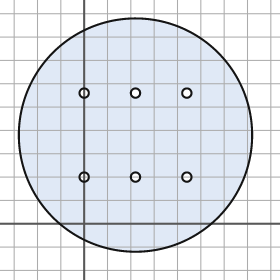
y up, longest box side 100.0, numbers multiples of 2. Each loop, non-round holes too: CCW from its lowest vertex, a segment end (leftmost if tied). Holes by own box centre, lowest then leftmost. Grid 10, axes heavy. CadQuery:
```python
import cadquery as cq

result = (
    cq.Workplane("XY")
    .moveTo(22.0, 38.0)
    .circle(50.0)
    .moveTo(0.0, 20.0)
    .circle(2.0)
    .moveTo(22.0, 20.0)
    .circle(2.0)
    .moveTo(44.0, 20.0)
    .circle(2.0)
    .moveTo(0.0, 56.0)
    .circle(2.0)
    .moveTo(22.0, 56.0)
    .circle(2.0)
    .moveTo(44.0, 56.0)
    .circle(2.0)
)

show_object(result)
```